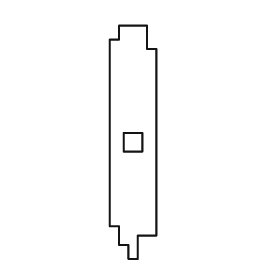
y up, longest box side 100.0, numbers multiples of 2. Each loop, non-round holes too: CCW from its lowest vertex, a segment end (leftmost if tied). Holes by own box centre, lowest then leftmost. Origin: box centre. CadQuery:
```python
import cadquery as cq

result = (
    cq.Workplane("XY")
    .moveTo(-2.0, -50.0)
    .lineTo(2.0, -50.0)
    .lineTo(2.0, -40.0)
    .lineTo(10.0, -40.0)
    .lineTo(10.0, 40.0)
    .lineTo(6.0, 40.0)
    .lineTo(6.0, 50.0)
    .lineTo(-6.0, 50.0)
    .lineTo(-6.0, 44.0)
    .lineTo(-10.0, 44.0)
    .lineTo(-10.0, -36.0)
    .lineTo(-6.0, -36.0)
    .lineTo(-6.0, -44.0)
    .lineTo(-2.0, -44.0)
    .close()
    .moveTo(-4.0, -4.0)
    .lineTo(4.0, -4.0)
    .lineTo(4.0, 4.0)
    .lineTo(-4.0, 4.0)
    .close()
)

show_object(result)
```